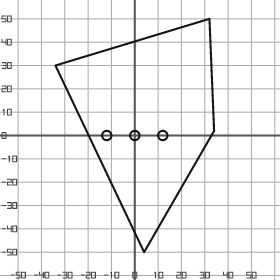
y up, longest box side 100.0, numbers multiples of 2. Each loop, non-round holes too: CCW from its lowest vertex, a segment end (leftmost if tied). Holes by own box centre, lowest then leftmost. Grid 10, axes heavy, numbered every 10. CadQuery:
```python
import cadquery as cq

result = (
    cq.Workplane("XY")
    .moveTo(4.0, -50.0)
    .lineTo(34.0, 2.0)
    .lineTo(32.0, 50.0)
    .lineTo(-34.0, 30.0)
    .close()
    .moveTo(-12.0, 0.0)
    .circle(2.0)
    .moveTo(0.0, 0.0)
    .circle(2.0)
    .moveTo(12.0, 0.0)
    .circle(2.0)
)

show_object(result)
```